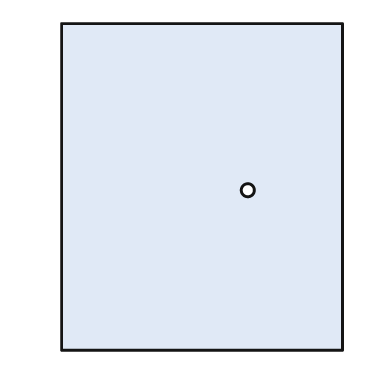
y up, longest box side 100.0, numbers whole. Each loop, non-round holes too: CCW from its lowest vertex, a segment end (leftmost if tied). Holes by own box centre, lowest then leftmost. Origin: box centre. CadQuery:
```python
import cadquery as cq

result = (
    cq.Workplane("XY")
    .moveTo(-43.0, -50.0)
    .lineTo(43.0, -50.0)
    .lineTo(43.0, 50.0)
    .lineTo(-43.0, 50.0)
    .close()
    .moveTo(14.0, -1.0)
    .circle(2.0)
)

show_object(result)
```